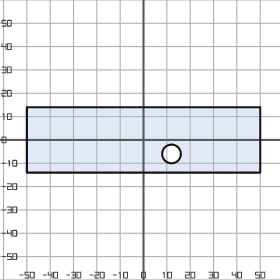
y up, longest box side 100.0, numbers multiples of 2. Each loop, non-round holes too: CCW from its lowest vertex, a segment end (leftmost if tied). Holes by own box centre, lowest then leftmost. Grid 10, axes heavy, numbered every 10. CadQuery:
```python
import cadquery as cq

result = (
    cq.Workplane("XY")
    .moveTo(-50.0, -14.0)
    .lineTo(50.0, -14.0)
    .lineTo(50.0, 14.0)
    .lineTo(-50.0, 14.0)
    .close()
    .moveTo(12.0, -6.0)
    .circle(4.0)
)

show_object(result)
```